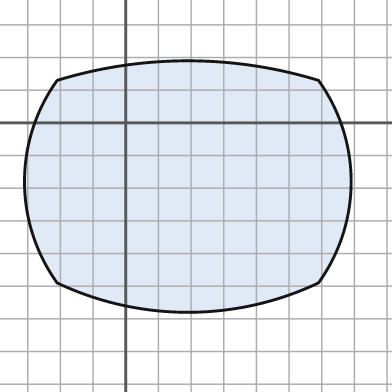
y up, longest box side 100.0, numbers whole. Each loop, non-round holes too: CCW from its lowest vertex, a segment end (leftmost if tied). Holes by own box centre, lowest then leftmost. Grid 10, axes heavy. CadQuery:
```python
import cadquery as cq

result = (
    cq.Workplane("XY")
    .moveTo(-21.0, -49.0)
    .threePointArc((19.0, -58.0), (59.0, -49.0))
    .threePointArc((69.0, -18.0), (59.0, 13.0))
    .threePointArc((19.0, 19.0), (-21.0, 13.0))
    .threePointArc((-31.0, -18.0), (-21.0, -49.0))
    .close()
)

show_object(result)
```